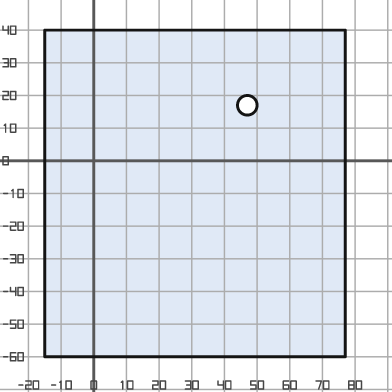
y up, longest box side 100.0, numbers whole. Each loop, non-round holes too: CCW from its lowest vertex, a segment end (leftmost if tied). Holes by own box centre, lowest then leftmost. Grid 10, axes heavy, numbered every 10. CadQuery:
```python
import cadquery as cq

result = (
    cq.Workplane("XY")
    .moveTo(-15.0, -60.0)
    .lineTo(77.0, -60.0)
    .lineTo(77.0, 40.0)
    .lineTo(-15.0, 40.0)
    .close()
    .moveTo(47.0, 17.0)
    .circle(3.0)
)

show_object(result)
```